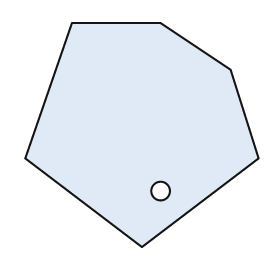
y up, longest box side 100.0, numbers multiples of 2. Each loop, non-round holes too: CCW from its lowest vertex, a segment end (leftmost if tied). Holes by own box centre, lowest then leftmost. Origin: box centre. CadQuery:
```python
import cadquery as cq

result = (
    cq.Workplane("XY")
    .moveTo(0.0, -48.0)
    .lineTo(50.0, -10.0)
    .lineTo(38.0, 28.0)
    .lineTo(8.0, 48.0)
    .lineTo(-30.0, 48.0)
    .lineTo(-50.0, -10.0)
    .close()
    .moveTo(8.0, -24.0)
    .circle(4.0)
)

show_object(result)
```